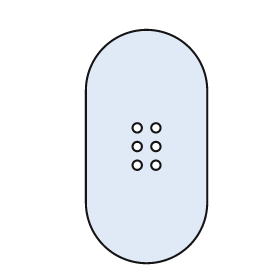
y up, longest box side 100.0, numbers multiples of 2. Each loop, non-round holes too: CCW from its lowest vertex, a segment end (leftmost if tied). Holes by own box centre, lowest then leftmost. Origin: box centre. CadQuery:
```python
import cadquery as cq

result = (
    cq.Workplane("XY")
    .moveTo(-26.0, -24.0)
    .threePointArc((0.0, -50.0), (26.0, -24.0))
    .lineTo(26.0, 24.0)
    .threePointArc((0.0, 50.0), (-26.0, 24.0))
    .close()
    .moveTo(-4.0, -8.0)
    .circle(2.0)
    .moveTo(4.0, -8.0)
    .circle(2.0)
    .moveTo(-4.0, 0.0)
    .circle(2.0)
    .moveTo(4.0, 0.0)
    .circle(2.0)
    .moveTo(-4.0, 8.0)
    .circle(2.0)
    .moveTo(4.0, 8.0)
    .circle(2.0)
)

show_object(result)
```